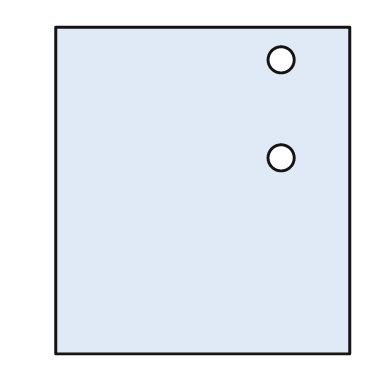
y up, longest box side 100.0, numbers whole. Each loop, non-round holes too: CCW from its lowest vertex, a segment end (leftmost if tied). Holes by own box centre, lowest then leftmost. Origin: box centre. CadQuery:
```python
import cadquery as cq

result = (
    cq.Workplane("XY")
    .moveTo(-45.0, -50.0)
    .lineTo(45.0, -50.0)
    .lineTo(45.0, 50.0)
    .lineTo(-45.0, 50.0)
    .close()
    .moveTo(24.0, 10.0)
    .circle(4.0)
    .moveTo(24.0, 40.0)
    .circle(4.0)
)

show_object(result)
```